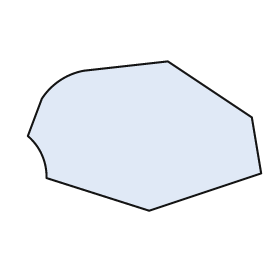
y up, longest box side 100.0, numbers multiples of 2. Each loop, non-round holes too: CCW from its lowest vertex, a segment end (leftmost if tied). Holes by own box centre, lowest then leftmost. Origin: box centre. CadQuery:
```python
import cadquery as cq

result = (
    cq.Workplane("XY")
    .moveTo(2.0, -32.0)
    .lineTo(50.0, -16.0)
    .lineTo(46.0, 8.0)
    .lineTo(10.0, 32.0)
    .lineTo(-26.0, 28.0)
    .threePointArc((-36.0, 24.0), (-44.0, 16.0))
    .lineTo(-50.0, 0.0)
    .threePointArc((-44.0, -8.0), (-42.0, -18.0))
    .close()
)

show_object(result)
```